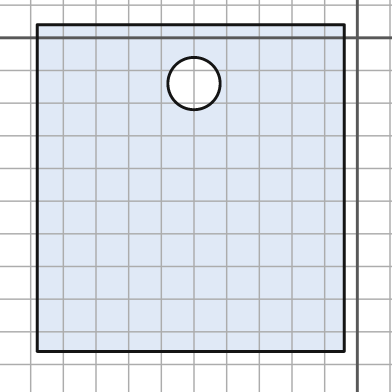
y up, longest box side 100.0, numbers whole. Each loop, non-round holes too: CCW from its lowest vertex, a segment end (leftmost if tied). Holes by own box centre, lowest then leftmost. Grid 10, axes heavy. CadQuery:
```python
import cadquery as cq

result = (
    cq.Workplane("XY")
    .moveTo(-98.0, -96.0)
    .lineTo(-4.0, -96.0)
    .lineTo(-4.0, 4.0)
    .lineTo(-98.0, 4.0)
    .close()
    .moveTo(-50.0, -14.0)
    .circle(8.0)
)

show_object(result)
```